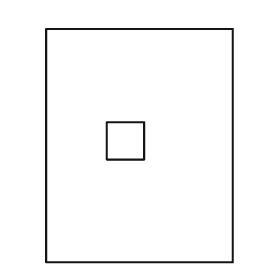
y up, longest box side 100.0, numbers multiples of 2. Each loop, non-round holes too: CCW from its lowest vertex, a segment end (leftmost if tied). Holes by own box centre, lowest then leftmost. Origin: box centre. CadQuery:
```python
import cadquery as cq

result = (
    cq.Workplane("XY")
    .moveTo(-40.0, -50.0)
    .lineTo(40.0, -50.0)
    .lineTo(40.0, 50.0)
    .lineTo(-40.0, 50.0)
    .close()
    .moveTo(-14.0, -6.0)
    .lineTo(2.0, -6.0)
    .lineTo(2.0, 10.0)
    .lineTo(-14.0, 10.0)
    .close()
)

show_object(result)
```